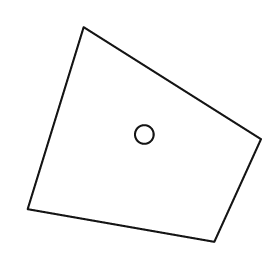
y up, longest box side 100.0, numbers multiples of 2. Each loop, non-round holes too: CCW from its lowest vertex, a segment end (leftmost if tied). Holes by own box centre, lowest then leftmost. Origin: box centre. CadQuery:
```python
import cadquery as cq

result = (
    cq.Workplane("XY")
    .moveTo(30.0, -46.0)
    .lineTo(50.0, -2.0)
    .lineTo(-26.0, 46.0)
    .lineTo(-50.0, -32.0)
    .close()
    .moveTo(0.0, 0.0)
    .circle(4.0)
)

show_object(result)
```